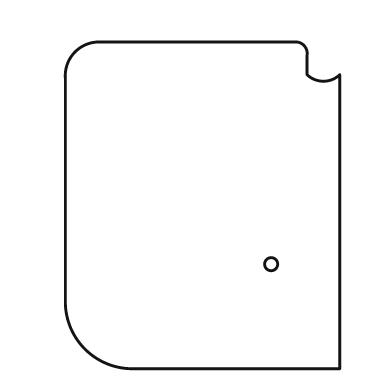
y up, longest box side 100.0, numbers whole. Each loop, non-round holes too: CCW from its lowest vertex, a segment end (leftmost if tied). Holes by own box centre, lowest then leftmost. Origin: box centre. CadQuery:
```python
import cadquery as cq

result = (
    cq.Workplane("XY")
    .moveTo(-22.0, -50.0)
    .lineTo(42.0, -50.0)
    .lineTo(42.0, 40.0)
    .threePointArc((37.0, 38.0), (32.0, 40.0))
    .lineTo(32.0, 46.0)
    .threePointArc((31.0, 49.0), (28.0, 50.0))
    .lineTo(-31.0, 50.0)
    .threePointArc((-39.0, 47.0), (-42.0, 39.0))
    .lineTo(-42.0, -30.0)
    .threePointArc((-36.0, -44.0), (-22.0, -50.0))
    .close()
    .moveTo(21.0, -18.0)
    .circle(2.0)
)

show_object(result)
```